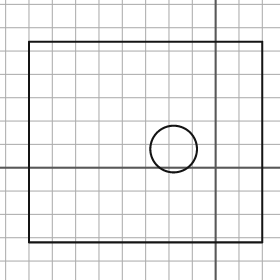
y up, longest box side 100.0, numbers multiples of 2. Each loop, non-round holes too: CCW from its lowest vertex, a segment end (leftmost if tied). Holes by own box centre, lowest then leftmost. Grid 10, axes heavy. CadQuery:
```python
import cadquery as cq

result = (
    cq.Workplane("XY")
    .moveTo(-80.0, -32.0)
    .lineTo(20.0, -32.0)
    .lineTo(20.0, 54.0)
    .lineTo(-80.0, 54.0)
    .close()
    .moveTo(-18.0, 8.0)
    .circle(10.0)
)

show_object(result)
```